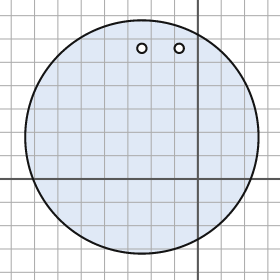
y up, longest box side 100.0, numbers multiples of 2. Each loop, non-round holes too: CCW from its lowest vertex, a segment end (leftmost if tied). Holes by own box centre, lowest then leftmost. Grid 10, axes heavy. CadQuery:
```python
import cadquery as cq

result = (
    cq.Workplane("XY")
    .moveTo(-24.0, 18.0)
    .circle(50.0)
    .moveTo(-24.0, 56.0)
    .circle(2.0)
    .moveTo(-8.0, 56.0)
    .circle(2.0)
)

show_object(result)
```